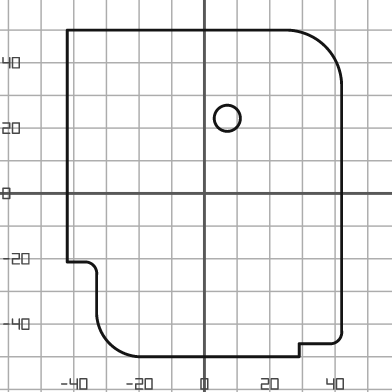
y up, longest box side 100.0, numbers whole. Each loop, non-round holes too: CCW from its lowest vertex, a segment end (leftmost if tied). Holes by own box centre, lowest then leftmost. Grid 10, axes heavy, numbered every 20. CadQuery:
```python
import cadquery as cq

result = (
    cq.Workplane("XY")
    .moveTo(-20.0, -50.0)
    .lineTo(29.0, -50.0)
    .lineTo(29.0, -46.0)
    .lineTo(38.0, -46.0)
    .threePointArc((41.0, -45.0), (42.0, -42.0))
    .lineTo(42.0, 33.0)
    .threePointArc((37.0, 45.0), (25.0, 50.0))
    .lineTo(-42.0, 50.0)
    .lineTo(-42.0, -21.0)
    .lineTo(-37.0, -21.0)
    .threePointArc((-34.0, -22.0), (-33.0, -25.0))
    .lineTo(-33.0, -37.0)
    .threePointArc((-29.0, -46.0), (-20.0, -50.0))
    .close()
    .moveTo(7.0, 23.0)
    .circle(4.0)
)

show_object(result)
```